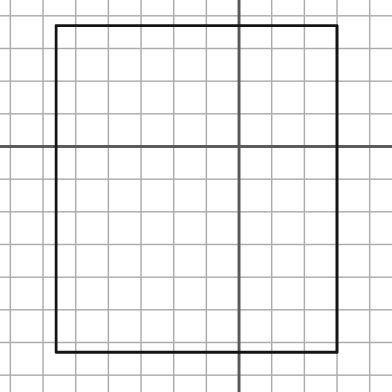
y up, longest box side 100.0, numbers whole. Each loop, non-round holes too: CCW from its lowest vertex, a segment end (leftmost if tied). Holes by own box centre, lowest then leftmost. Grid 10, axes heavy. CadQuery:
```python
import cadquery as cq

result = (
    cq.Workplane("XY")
    .moveTo(-56.0, -63.0)
    .lineTo(30.0, -63.0)
    .lineTo(30.0, 37.0)
    .lineTo(-56.0, 37.0)
    .close()
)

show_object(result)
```